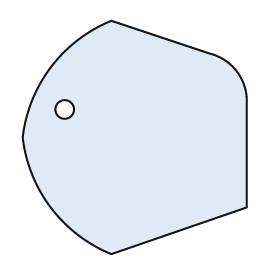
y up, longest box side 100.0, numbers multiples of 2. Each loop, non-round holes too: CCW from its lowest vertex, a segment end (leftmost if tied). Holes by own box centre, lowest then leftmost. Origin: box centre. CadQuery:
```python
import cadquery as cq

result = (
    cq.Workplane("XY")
    .moveTo(-10.0, -50.0)
    .lineTo(48.0, -30.0)
    .lineTo(48.0, 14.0)
    .threePointArc((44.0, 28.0), (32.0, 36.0))
    .lineTo(-10.0, 50.0)
    .threePointArc((-36.0, 30.0), (-48.0, 0.0))
    .threePointArc((-36.0, -30.0), (-10.0, -50.0))
    .close()
    .moveTo(-30.0, 12.0)
    .circle(4.0)
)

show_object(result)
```